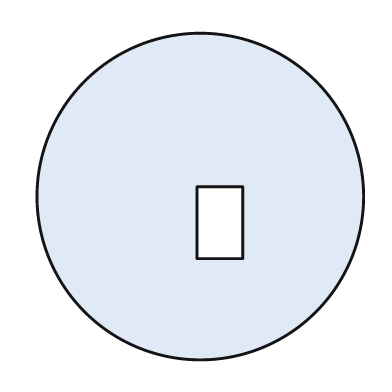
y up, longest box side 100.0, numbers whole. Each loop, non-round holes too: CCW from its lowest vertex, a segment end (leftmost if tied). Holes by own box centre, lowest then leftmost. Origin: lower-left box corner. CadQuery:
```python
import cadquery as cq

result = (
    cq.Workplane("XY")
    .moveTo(50.0, 50.0)
    .circle(50.0)
    .moveTo(49.0, 31.0)
    .lineTo(63.0, 31.0)
    .lineTo(63.0, 53.0)
    .lineTo(49.0, 53.0)
    .close()
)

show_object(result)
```